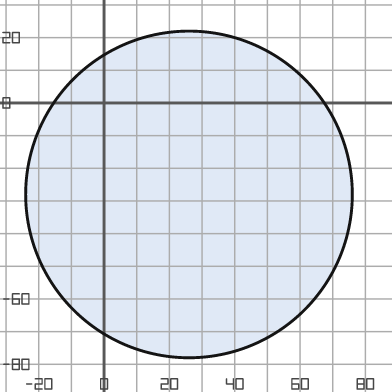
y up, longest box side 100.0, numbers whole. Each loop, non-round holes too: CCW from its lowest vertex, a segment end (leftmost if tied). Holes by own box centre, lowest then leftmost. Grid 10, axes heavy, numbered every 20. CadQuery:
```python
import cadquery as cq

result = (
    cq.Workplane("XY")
    .moveTo(26.0, -28.0)
    .circle(50.0)
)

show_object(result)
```